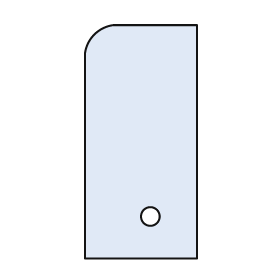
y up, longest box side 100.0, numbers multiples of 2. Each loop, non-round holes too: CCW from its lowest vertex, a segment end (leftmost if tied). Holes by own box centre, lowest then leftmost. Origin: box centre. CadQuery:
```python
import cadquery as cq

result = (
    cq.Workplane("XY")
    .moveTo(-24.0, -50.0)
    .lineTo(24.0, -50.0)
    .lineTo(24.0, 50.0)
    .lineTo(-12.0, 50.0)
    .threePointArc((-20.0, 46.0), (-24.0, 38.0))
    .close()
    .moveTo(4.0, -32.0)
    .circle(4.0)
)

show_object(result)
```